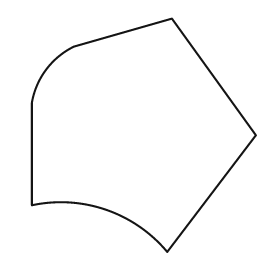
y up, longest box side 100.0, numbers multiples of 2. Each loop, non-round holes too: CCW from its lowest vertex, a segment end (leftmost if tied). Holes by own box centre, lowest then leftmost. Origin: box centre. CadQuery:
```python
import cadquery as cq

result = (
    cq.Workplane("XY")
    .moveTo(10.0, -50.0)
    .lineTo(48.0, 0.0)
    .lineTo(12.0, 50.0)
    .lineTo(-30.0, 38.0)
    .threePointArc((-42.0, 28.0), (-48.0, 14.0))
    .lineTo(-48.0, -30.0)
    .threePointArc((-16.0, -32.0), (10.0, -50.0))
    .close()
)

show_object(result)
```